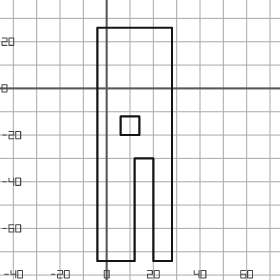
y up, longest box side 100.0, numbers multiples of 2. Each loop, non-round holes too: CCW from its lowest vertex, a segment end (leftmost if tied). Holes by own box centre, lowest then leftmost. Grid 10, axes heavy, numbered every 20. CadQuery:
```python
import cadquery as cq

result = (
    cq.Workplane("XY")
    .moveTo(-4.0, -74.0)
    .lineTo(12.0, -74.0)
    .lineTo(12.0, -30.0)
    .lineTo(20.0, -30.0)
    .lineTo(20.0, -74.0)
    .lineTo(28.0, -74.0)
    .lineTo(28.0, 26.0)
    .lineTo(-4.0, 26.0)
    .close()
    .moveTo(6.0, -20.0)
    .lineTo(14.0, -20.0)
    .lineTo(14.0, -12.0)
    .lineTo(6.0, -12.0)
    .close()
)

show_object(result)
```